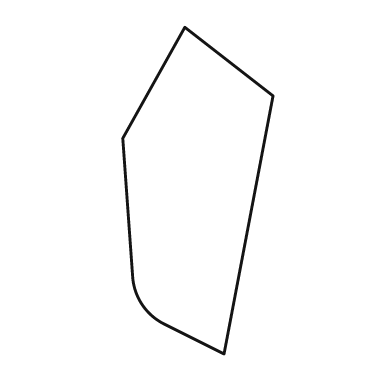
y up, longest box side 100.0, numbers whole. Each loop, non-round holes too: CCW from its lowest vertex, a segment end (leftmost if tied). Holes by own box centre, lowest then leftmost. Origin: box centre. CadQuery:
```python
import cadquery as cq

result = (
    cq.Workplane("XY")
    .moveTo(8.0, -50.0)
    .lineTo(23.0, 29.0)
    .lineTo(-4.0, 50.0)
    .lineTo(-23.0, 16.0)
    .lineTo(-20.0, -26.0)
    .threePointArc((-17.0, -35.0), (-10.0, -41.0))
    .close()
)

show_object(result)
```